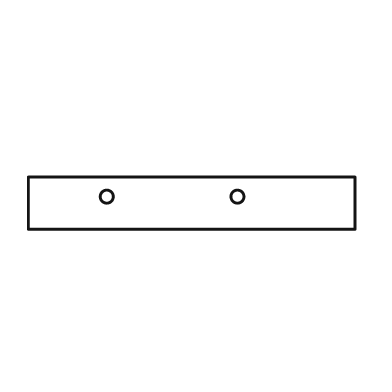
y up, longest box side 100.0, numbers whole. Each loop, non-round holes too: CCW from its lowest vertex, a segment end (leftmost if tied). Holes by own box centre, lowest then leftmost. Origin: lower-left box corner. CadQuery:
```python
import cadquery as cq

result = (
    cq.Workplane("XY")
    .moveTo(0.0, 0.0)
    .lineTo(100.0, 0.0)
    .lineTo(100.0, 16.0)
    .lineTo(0.0, 16.0)
    .close()
    .moveTo(24.0, 10.0)
    .circle(2.0)
    .moveTo(64.0, 10.0)
    .circle(2.0)
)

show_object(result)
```